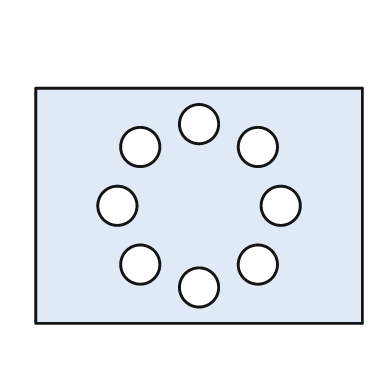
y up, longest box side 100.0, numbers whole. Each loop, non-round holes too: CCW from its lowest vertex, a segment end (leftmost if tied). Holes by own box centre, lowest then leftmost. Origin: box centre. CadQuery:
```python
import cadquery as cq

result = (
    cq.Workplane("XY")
    .moveTo(-50.0, -36.0)
    .lineTo(50.0, -36.0)
    .lineTo(50.0, 36.0)
    .lineTo(-50.0, 36.0)
    .close()
    .moveTo(0.0, -25.0)
    .circle(6.0)
    .moveTo(-18.0, -18.0)
    .circle(6.0)
    .moveTo(18.0, -18.0)
    .circle(6.0)
    .moveTo(-25.0, 0.0)
    .circle(6.0)
    .moveTo(25.0, 0.0)
    .circle(6.0)
    .moveTo(-18.0, 18.0)
    .circle(6.0)
    .moveTo(18.0, 18.0)
    .circle(6.0)
    .moveTo(0.0, 25.0)
    .circle(6.0)
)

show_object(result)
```